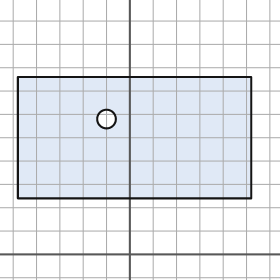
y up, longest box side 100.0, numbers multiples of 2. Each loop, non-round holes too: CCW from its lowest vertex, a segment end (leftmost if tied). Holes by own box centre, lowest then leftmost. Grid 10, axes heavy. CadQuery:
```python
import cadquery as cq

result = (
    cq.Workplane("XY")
    .moveTo(-48.0, 24.0)
    .lineTo(52.0, 24.0)
    .lineTo(52.0, 76.0)
    .lineTo(-48.0, 76.0)
    .close()
    .moveTo(-10.0, 58.0)
    .circle(4.0)
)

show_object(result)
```